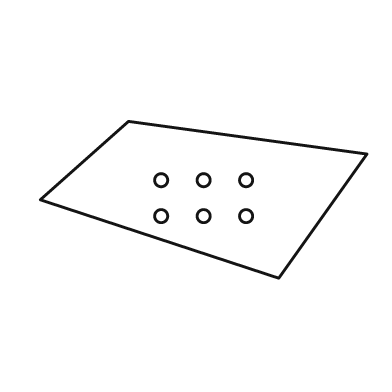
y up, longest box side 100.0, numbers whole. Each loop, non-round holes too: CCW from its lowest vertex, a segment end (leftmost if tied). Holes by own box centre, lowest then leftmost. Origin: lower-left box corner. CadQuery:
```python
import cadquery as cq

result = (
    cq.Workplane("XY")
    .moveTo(73.0, 0.0)
    .lineTo(100.0, 38.0)
    .lineTo(27.0, 48.0)
    .lineTo(0.0, 24.0)
    .close()
    .moveTo(37.0, 19.0)
    .circle(2.0)
    .moveTo(50.0, 19.0)
    .circle(2.0)
    .moveTo(63.0, 19.0)
    .circle(2.0)
    .moveTo(37.0, 30.0)
    .circle(2.0)
    .moveTo(50.0, 30.0)
    .circle(2.0)
    .moveTo(63.0, 30.0)
    .circle(2.0)
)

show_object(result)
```